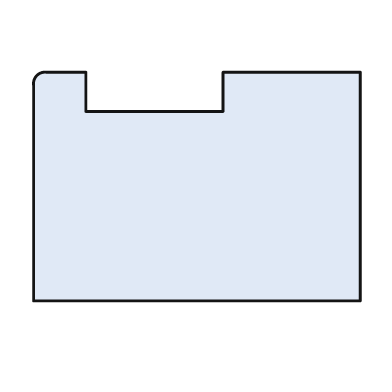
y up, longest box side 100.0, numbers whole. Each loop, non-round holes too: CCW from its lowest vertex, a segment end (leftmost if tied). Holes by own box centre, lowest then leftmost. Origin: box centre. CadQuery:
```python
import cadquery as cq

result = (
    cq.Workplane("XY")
    .moveTo(-50.0, -35.0)
    .lineTo(50.0, -35.0)
    .lineTo(50.0, 35.0)
    .lineTo(8.0, 35.0)
    .lineTo(8.0, 23.0)
    .lineTo(-34.0, 23.0)
    .lineTo(-34.0, 35.0)
    .lineTo(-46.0, 35.0)
    .threePointArc((-49.0, 34.0), (-50.0, 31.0))
    .close()
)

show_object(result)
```